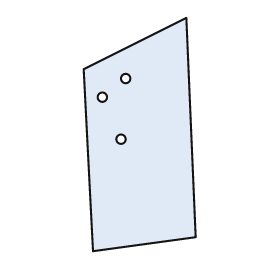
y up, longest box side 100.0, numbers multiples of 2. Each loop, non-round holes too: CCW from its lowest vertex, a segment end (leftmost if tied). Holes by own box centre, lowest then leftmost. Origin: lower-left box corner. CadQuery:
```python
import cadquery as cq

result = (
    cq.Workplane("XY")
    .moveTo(4.0, 0.0)
    .lineTo(48.0, 6.0)
    .lineTo(44.0, 100.0)
    .lineTo(0.0, 78.0)
    .close()
    .moveTo(16.0, 48.0)
    .circle(2.0)
    .moveTo(8.0, 66.0)
    .circle(2.0)
    .moveTo(18.0, 74.0)
    .circle(2.0)
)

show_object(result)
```